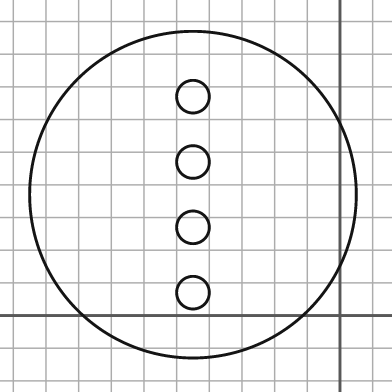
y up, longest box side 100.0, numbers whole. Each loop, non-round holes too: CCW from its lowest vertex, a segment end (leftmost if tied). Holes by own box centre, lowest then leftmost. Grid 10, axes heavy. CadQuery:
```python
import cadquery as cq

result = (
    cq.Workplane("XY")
    .moveTo(-45.0, 37.0)
    .circle(50.0)
    .moveTo(-45.0, 7.0)
    .circle(5.0)
    .moveTo(-45.0, 27.0)
    .circle(5.0)
    .moveTo(-45.0, 47.0)
    .circle(5.0)
    .moveTo(-45.0, 67.0)
    .circle(5.0)
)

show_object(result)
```